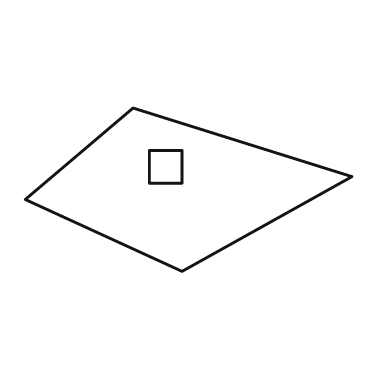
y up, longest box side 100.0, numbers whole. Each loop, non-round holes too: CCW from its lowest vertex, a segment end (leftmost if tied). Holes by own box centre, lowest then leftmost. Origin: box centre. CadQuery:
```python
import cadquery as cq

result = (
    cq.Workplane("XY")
    .moveTo(-2.0, -25.0)
    .lineTo(50.0, 4.0)
    .lineTo(-17.0, 25.0)
    .lineTo(-50.0, -3.0)
    .close()
    .moveTo(-12.0, 2.0)
    .lineTo(-2.0, 2.0)
    .lineTo(-2.0, 12.0)
    .lineTo(-12.0, 12.0)
    .close()
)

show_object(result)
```